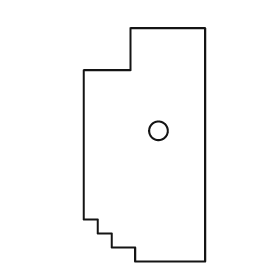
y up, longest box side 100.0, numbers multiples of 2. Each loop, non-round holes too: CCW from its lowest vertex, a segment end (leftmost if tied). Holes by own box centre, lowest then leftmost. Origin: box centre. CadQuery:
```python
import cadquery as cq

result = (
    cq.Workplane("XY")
    .moveTo(-4.0, -50.0)
    .lineTo(26.0, -50.0)
    .lineTo(26.0, 50.0)
    .lineTo(-6.0, 50.0)
    .lineTo(-6.0, 32.0)
    .lineTo(-26.0, 32.0)
    .lineTo(-26.0, -32.0)
    .lineTo(-20.0, -32.0)
    .lineTo(-20.0, -38.0)
    .lineTo(-14.0, -38.0)
    .lineTo(-14.0, -44.0)
    .lineTo(-4.0, -44.0)
    .close()
    .moveTo(6.0, 6.0)
    .circle(4.0)
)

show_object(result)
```